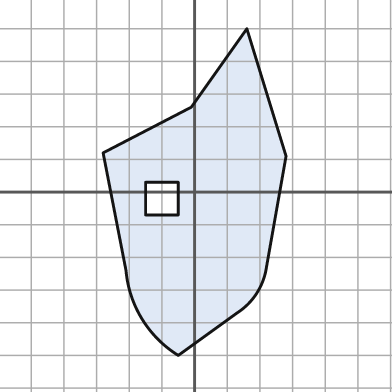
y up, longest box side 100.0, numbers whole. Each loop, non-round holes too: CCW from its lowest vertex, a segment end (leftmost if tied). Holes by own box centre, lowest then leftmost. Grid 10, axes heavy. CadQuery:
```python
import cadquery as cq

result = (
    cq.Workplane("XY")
    .moveTo(-5.0, -50.0)
    .lineTo(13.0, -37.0)
    .threePointArc((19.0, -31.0), (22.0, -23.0))
    .lineTo(28.0, 11.0)
    .lineTo(16.0, 50.0)
    .lineTo(-1.0, 26.0)
    .lineTo(-28.0, 12.0)
    .lineTo(-21.0, -24.0)
    .threePointArc((-16.0, -39.0), (-5.0, -50.0))
    .close()
    .moveTo(-15.0, -7.0)
    .lineTo(-5.0, -7.0)
    .lineTo(-5.0, 3.0)
    .lineTo(-15.0, 3.0)
    .close()
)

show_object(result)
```